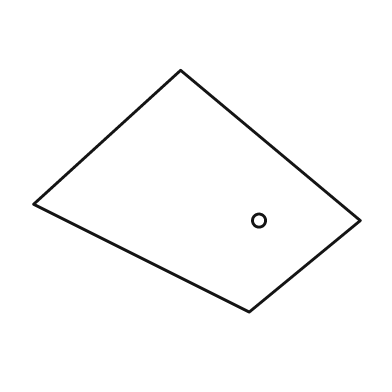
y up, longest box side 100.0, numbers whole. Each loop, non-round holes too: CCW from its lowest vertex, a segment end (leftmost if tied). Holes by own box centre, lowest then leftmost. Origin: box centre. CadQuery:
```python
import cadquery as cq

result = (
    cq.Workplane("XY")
    .moveTo(16.0, -37.0)
    .lineTo(50.0, -9.0)
    .lineTo(-5.0, 37.0)
    .lineTo(-50.0, -4.0)
    .close()
    .moveTo(19.0, -9.0)
    .circle(2.0)
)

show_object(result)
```